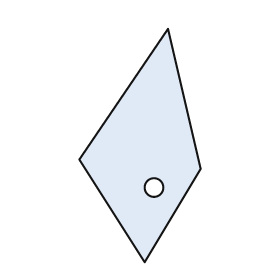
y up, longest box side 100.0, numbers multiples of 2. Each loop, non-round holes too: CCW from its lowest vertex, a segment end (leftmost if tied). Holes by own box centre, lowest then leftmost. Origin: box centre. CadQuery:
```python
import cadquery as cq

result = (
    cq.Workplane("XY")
    .moveTo(2.0, -50.0)
    .lineTo(26.0, -10.0)
    .lineTo(12.0, 50.0)
    .lineTo(-26.0, -6.0)
    .close()
    .moveTo(6.0, -18.0)
    .circle(4.0)
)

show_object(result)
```